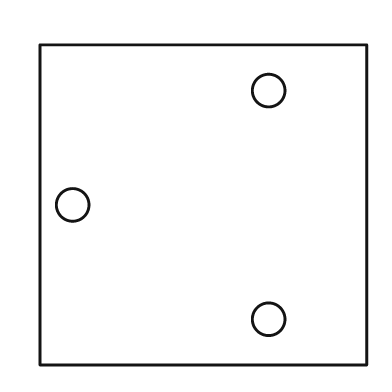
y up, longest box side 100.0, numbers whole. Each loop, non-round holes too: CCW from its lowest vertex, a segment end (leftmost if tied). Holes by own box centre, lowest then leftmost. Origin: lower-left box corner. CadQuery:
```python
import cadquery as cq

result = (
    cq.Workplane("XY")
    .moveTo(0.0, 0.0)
    .lineTo(100.0, 0.0)
    .lineTo(100.0, 98.0)
    .lineTo(0.0, 98.0)
    .close()
    .moveTo(70.0, 14.0)
    .circle(5.0)
    .moveTo(10.0, 49.0)
    .circle(5.0)
    .moveTo(70.0, 84.0)
    .circle(5.0)
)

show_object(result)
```